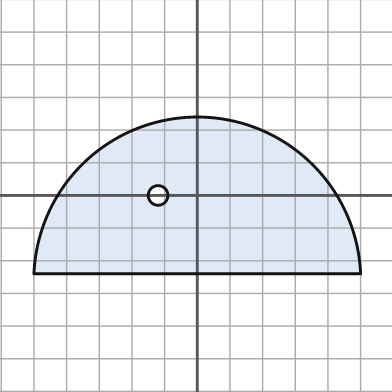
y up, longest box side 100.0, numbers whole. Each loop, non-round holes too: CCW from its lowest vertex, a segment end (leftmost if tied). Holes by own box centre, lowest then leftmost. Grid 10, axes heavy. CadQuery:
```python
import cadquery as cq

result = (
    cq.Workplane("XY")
    .moveTo(-50.0, -24.0)
    .lineTo(50.0, -24.0)
    .threePointArc((0.0, 24.0), (-50.0, -24.0))
    .close()
    .moveTo(-12.0, 0.0)
    .circle(3.0)
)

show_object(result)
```